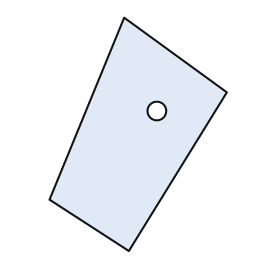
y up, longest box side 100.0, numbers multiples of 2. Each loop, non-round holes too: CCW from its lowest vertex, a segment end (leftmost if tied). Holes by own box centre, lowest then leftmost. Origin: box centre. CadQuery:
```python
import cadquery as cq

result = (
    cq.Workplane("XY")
    .moveTo(-4.0, -50.0)
    .lineTo(38.0, 18.0)
    .lineTo(-6.0, 50.0)
    .lineTo(-38.0, -28.0)
    .close()
    .moveTo(8.0, 10.0)
    .circle(4.0)
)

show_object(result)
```